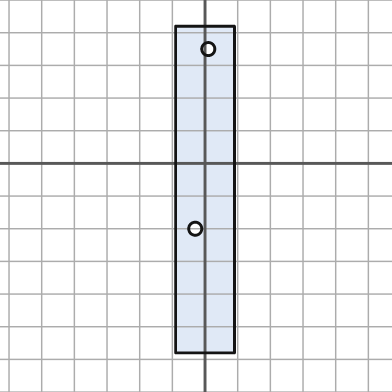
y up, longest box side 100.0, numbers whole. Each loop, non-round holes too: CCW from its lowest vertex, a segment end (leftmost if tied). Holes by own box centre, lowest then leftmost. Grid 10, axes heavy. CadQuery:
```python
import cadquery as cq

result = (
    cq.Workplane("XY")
    .moveTo(-9.0, -58.0)
    .lineTo(9.0, -58.0)
    .lineTo(9.0, 42.0)
    .lineTo(-9.0, 42.0)
    .close()
    .moveTo(-3.0, -20.0)
    .circle(2.0)
    .moveTo(1.0, 35.0)
    .circle(2.0)
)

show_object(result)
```